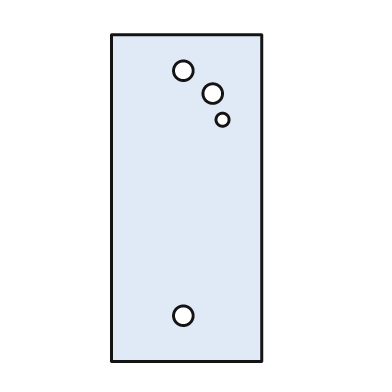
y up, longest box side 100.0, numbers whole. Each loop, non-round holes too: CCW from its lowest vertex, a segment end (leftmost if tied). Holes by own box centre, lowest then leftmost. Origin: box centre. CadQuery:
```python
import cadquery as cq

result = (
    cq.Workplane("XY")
    .moveTo(-23.0, -50.0)
    .lineTo(23.0, -50.0)
    .lineTo(23.0, 50.0)
    .lineTo(-23.0, 50.0)
    .close()
    .moveTo(-1.0, -36.0)
    .circle(3.0)
    .moveTo(11.0, 24.0)
    .circle(2.0)
    .moveTo(8.0, 32.0)
    .circle(3.0)
    .moveTo(-1.0, 39.0)
    .circle(3.0)
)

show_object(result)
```